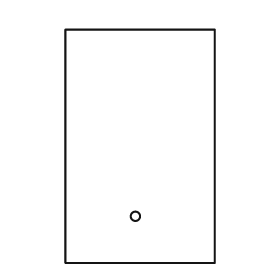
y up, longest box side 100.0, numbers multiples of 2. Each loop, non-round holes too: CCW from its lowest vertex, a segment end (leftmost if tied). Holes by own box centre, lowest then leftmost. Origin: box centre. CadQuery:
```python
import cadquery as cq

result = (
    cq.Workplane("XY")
    .moveTo(-32.0, -50.0)
    .lineTo(32.0, -50.0)
    .lineTo(32.0, 50.0)
    .lineTo(-32.0, 50.0)
    .close()
    .moveTo(-2.0, -30.0)
    .circle(2.0)
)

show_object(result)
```